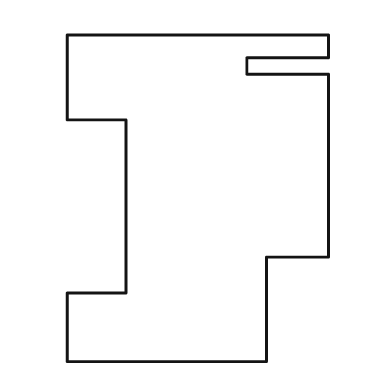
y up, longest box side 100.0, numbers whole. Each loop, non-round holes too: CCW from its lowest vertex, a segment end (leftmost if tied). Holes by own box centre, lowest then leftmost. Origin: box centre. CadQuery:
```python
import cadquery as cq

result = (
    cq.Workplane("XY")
    .moveTo(-40.0, -50.0)
    .lineTo(21.0, -50.0)
    .lineTo(21.0, -18.0)
    .lineTo(40.0, -18.0)
    .lineTo(40.0, 38.0)
    .lineTo(15.0, 38.0)
    .lineTo(15.0, 43.0)
    .lineTo(40.0, 43.0)
    .lineTo(40.0, 50.0)
    .lineTo(-40.0, 50.0)
    .lineTo(-40.0, 24.0)
    .lineTo(-22.0, 24.0)
    .lineTo(-22.0, -29.0)
    .lineTo(-40.0, -29.0)
    .close()
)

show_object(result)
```